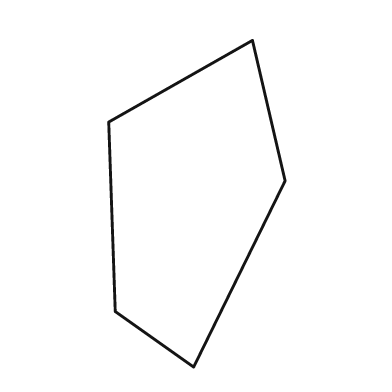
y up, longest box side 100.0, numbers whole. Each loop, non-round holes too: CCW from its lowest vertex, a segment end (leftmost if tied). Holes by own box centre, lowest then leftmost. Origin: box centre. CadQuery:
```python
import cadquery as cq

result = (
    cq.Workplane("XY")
    .moveTo(-1.0, -50.0)
    .lineTo(27.0, 7.0)
    .lineTo(17.0, 50.0)
    .lineTo(-27.0, 25.0)
    .lineTo(-25.0, -33.0)
    .close()
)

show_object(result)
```